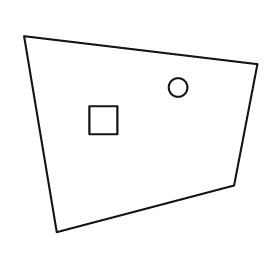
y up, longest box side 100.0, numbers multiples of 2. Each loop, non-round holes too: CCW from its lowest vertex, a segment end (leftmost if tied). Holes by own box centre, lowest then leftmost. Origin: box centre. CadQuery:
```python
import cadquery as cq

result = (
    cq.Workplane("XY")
    .moveTo(-36.0, -42.0)
    .lineTo(40.0, -22.0)
    .lineTo(50.0, 30.0)
    .lineTo(-50.0, 42.0)
    .close()
    .moveTo(-22.0, 0.0)
    .lineTo(-10.0, 0.0)
    .lineTo(-10.0, 12.0)
    .lineTo(-22.0, 12.0)
    .close()
    .moveTo(16.0, 20.0)
    .circle(4.0)
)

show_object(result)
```